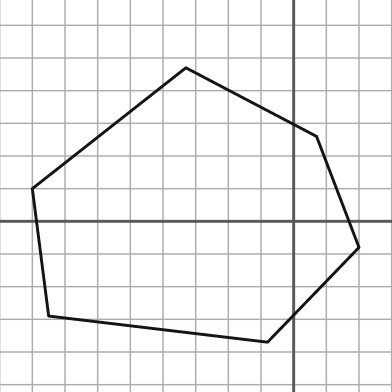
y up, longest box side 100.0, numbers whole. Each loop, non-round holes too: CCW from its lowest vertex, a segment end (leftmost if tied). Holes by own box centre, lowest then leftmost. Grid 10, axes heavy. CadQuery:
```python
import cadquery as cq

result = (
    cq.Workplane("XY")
    .moveTo(-8.0, -37.0)
    .lineTo(20.0, -8.0)
    .lineTo(7.0, 26.0)
    .lineTo(-33.0, 47.0)
    .lineTo(-80.0, 10.0)
    .lineTo(-75.0, -29.0)
    .close()
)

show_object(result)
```